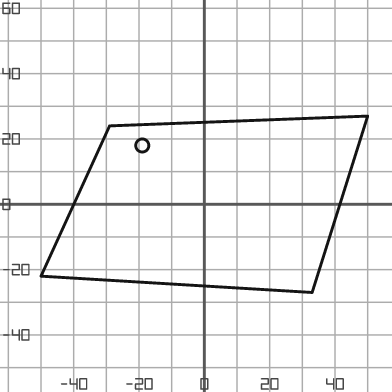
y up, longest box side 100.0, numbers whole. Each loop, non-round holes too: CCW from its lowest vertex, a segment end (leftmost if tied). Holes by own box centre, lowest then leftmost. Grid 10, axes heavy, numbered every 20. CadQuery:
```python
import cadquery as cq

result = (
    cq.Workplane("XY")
    .moveTo(33.0, -27.0)
    .lineTo(50.0, 27.0)
    .lineTo(-29.0, 24.0)
    .lineTo(-50.0, -22.0)
    .close()
    .moveTo(-19.0, 18.0)
    .circle(2.0)
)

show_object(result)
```